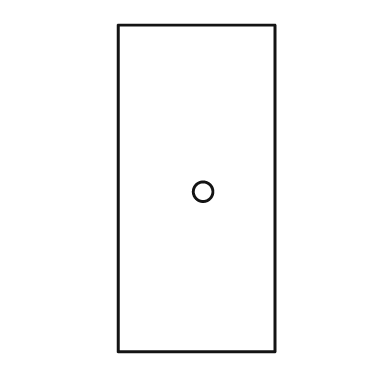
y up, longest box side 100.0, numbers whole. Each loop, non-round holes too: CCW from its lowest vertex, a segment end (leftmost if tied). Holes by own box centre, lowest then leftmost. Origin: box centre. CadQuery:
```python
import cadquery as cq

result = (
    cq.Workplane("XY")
    .moveTo(-24.0, -50.0)
    .lineTo(24.0, -50.0)
    .lineTo(24.0, 50.0)
    .lineTo(-24.0, 50.0)
    .close()
    .moveTo(2.0, -1.0)
    .circle(3.0)
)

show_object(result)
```